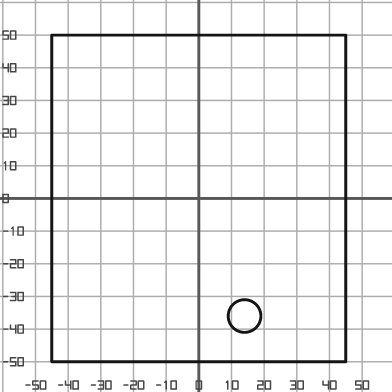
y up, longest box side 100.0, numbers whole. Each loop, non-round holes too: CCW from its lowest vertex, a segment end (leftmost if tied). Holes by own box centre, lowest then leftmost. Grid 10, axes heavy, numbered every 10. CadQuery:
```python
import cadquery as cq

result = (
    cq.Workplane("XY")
    .moveTo(-45.0, -50.0)
    .lineTo(45.0, -50.0)
    .lineTo(45.0, 50.0)
    .lineTo(-45.0, 50.0)
    .close()
    .moveTo(14.0, -36.0)
    .circle(5.0)
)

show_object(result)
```